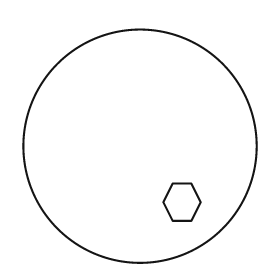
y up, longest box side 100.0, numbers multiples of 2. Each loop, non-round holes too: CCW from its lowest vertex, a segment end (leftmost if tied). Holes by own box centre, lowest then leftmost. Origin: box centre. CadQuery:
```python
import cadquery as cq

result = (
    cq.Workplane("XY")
    .moveTo(0.0, 0.0)
    .circle(50.0)
    .moveTo(14.0, -32.0)
    .lineTo(22.0, -32.0)
    .lineTo(26.0, -24.0)
    .lineTo(22.0, -16.0)
    .lineTo(14.0, -16.0)
    .lineTo(10.0, -24.0)
    .close()
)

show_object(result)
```